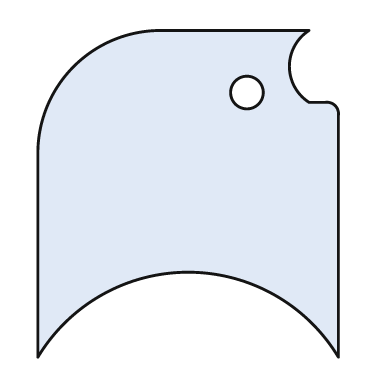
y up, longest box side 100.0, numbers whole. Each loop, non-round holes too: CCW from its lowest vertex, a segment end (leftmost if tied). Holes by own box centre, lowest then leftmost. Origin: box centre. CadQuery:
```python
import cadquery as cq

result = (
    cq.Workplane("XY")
    .moveTo(-46.0, -50.0)
    .threePointArc((0.0, -24.0), (46.0, -50.0))
    .lineTo(46.0, 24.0)
    .threePointArc((45.0, 27.0), (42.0, 28.0))
    .lineTo(37.0, 28.0)
    .threePointArc((31.0, 39.0), (37.0, 50.0))
    .lineTo(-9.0, 50.0)
    .threePointArc((-35.0, 39.0), (-46.0, 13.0))
    .close()
    .moveTo(18.0, 31.0)
    .circle(5.0)
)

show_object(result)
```